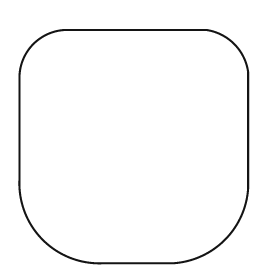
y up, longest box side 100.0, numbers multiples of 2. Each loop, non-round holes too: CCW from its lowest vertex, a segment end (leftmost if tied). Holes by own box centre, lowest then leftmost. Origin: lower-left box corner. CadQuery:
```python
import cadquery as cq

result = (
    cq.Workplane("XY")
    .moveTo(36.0, 0.0)
    .lineTo(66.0, 0.0)
    .threePointArc((88.0, 10.0), (98.0, 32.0))
    .lineTo(98.0, 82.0)
    .threePointArc((92.0, 94.0), (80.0, 100.0))
    .lineTo(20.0, 100.0)
    .threePointArc((6.0, 94.0), (0.0, 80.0))
    .lineTo(0.0, 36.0)
    .threePointArc((10.0, 10.0), (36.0, 0.0))
    .close()
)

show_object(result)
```